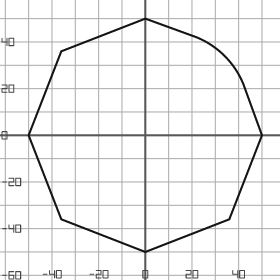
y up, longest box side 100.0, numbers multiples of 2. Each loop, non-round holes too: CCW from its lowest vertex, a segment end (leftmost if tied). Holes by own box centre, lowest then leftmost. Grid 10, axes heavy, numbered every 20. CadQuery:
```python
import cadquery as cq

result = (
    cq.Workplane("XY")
    .moveTo(0.0, -50.0)
    .lineTo(36.0, -36.0)
    .lineTo(50.0, 0.0)
    .lineTo(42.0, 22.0)
    .threePointArc((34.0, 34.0), (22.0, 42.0))
    .lineTo(0.0, 50.0)
    .lineTo(-36.0, 36.0)
    .lineTo(-50.0, 0.0)
    .lineTo(-36.0, -36.0)
    .close()
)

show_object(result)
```